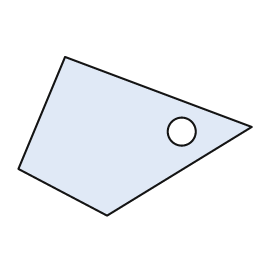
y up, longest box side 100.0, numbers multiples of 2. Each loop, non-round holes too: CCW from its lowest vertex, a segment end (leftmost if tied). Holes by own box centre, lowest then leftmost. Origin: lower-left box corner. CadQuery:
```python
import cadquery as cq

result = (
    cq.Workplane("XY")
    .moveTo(38.0, 0.0)
    .lineTo(100.0, 38.0)
    .lineTo(20.0, 68.0)
    .lineTo(0.0, 20.0)
    .close()
    .moveTo(70.0, 36.0)
    .circle(6.0)
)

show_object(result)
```